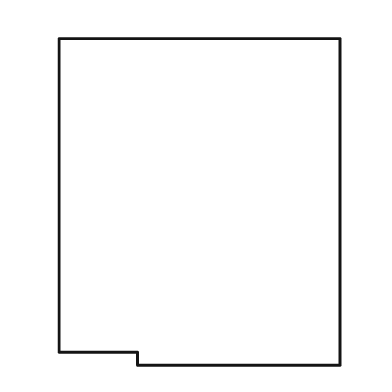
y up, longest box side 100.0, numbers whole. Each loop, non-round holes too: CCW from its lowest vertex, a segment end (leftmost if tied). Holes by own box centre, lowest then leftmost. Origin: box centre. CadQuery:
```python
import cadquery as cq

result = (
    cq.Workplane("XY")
    .moveTo(-19.0, -50.0)
    .lineTo(43.0, -50.0)
    .lineTo(43.0, 50.0)
    .lineTo(-43.0, 50.0)
    .lineTo(-43.0, -46.0)
    .lineTo(-19.0, -46.0)
    .close()
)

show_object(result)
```